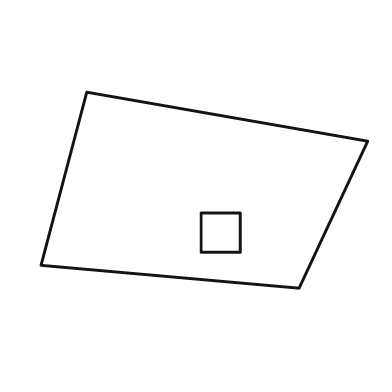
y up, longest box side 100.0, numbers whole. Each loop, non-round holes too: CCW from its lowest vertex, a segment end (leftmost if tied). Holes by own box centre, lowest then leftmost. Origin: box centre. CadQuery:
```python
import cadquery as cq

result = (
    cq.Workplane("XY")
    .moveTo(29.0, -30.0)
    .lineTo(50.0, 15.0)
    .lineTo(-36.0, 30.0)
    .lineTo(-50.0, -23.0)
    .close()
    .moveTo(-1.0, -19.0)
    .lineTo(11.0, -19.0)
    .lineTo(11.0, -7.0)
    .lineTo(-1.0, -7.0)
    .close()
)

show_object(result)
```